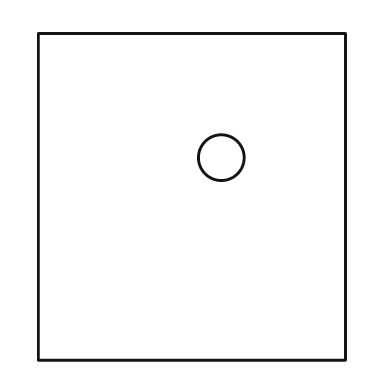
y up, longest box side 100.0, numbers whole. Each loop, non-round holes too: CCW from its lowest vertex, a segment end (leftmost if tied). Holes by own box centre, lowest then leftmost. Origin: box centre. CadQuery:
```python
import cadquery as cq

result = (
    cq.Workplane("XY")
    .moveTo(-47.0, -50.0)
    .lineTo(47.0, -50.0)
    .lineTo(47.0, 50.0)
    .lineTo(-47.0, 50.0)
    .close()
    .moveTo(9.0, 12.0)
    .circle(7.0)
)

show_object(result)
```